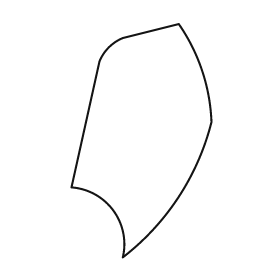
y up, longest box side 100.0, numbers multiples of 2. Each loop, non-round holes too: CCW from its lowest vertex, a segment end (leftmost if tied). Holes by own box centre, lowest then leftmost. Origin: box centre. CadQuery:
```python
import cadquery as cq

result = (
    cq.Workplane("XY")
    .moveTo(-8.0, -50.0)
    .threePointArc((16.0, -24.0), (30.0, 8.0))
    .threePointArc((26.0, 30.0), (16.0, 50.0))
    .lineTo(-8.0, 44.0)
    .threePointArc((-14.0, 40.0), (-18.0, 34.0))
    .lineTo(-30.0, -20.0)
    .threePointArc((-12.0, -30.0), (-8.0, -50.0))
    .close()
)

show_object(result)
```